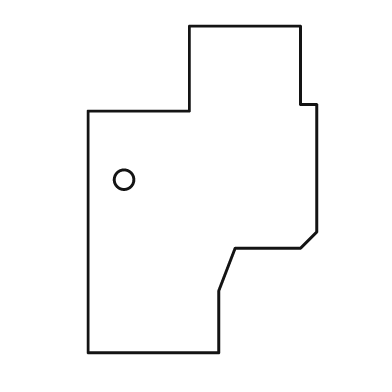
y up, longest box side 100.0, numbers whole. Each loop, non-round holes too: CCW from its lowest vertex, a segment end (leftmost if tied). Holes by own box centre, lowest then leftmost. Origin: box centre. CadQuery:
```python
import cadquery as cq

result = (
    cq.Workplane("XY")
    .moveTo(-35.0, -50.0)
    .lineTo(5.0, -50.0)
    .lineTo(5.0, -31.0)
    .lineTo(10.0, -18.0)
    .lineTo(30.0, -18.0)
    .lineTo(35.0, -13.0)
    .lineTo(35.0, 26.0)
    .lineTo(30.0, 26.0)
    .lineTo(30.0, 50.0)
    .lineTo(-4.0, 50.0)
    .lineTo(-4.0, 24.0)
    .lineTo(-35.0, 24.0)
    .close()
    .moveTo(-24.0, 3.0)
    .circle(3.0)
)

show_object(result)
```